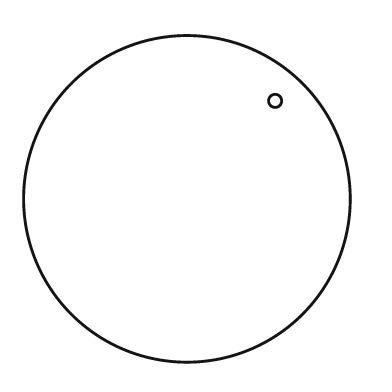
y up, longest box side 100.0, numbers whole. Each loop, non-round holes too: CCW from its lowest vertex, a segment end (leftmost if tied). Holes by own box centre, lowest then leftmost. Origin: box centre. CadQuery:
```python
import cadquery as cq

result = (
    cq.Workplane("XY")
    .moveTo(0.0, 0.0)
    .circle(50.0)
    .moveTo(27.0, 30.0)
    .circle(2.0)
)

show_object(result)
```